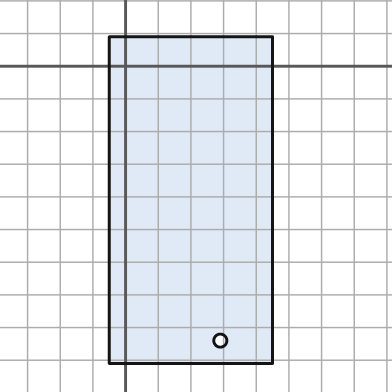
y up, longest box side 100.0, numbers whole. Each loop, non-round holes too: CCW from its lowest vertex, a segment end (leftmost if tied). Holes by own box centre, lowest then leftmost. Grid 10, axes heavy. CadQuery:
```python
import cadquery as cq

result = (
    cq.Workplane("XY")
    .moveTo(-5.0, -91.0)
    .lineTo(45.0, -91.0)
    .lineTo(45.0, 9.0)
    .lineTo(-5.0, 9.0)
    .close()
    .moveTo(29.0, -84.0)
    .circle(2.0)
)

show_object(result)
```